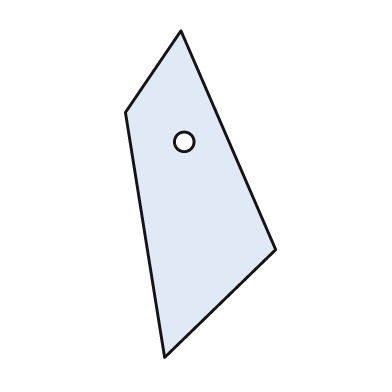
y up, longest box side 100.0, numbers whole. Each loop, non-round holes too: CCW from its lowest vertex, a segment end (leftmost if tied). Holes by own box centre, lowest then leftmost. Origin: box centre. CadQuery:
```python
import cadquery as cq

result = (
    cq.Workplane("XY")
    .moveTo(-11.0, -50.0)
    .lineTo(23.0, -17.0)
    .lineTo(-6.0, 50.0)
    .lineTo(-23.0, 25.0)
    .close()
    .moveTo(-5.0, 16.0)
    .circle(3.0)
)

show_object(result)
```